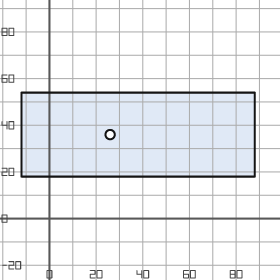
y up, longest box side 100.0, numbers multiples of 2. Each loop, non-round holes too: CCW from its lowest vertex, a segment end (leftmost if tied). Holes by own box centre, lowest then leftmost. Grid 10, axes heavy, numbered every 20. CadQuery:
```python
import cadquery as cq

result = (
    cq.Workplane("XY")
    .moveTo(-12.0, 18.0)
    .lineTo(88.0, 18.0)
    .lineTo(88.0, 54.0)
    .lineTo(-12.0, 54.0)
    .close()
    .moveTo(26.0, 36.0)
    .circle(2.0)
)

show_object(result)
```